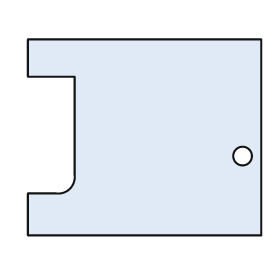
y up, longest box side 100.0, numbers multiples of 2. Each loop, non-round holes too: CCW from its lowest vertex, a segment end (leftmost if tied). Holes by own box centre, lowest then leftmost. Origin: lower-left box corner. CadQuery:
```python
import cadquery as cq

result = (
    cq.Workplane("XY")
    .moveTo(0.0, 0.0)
    .lineTo(100.0, 0.0)
    .lineTo(100.0, 84.0)
    .lineTo(0.0, 84.0)
    .lineTo(0.0, 68.0)
    .lineTo(20.0, 68.0)
    .lineTo(20.0, 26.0)
    .threePointArc((18.0, 20.0), (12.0, 18.0))
    .lineTo(0.0, 18.0)
    .close()
    .moveTo(92.0, 34.0)
    .circle(4.0)
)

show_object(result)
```